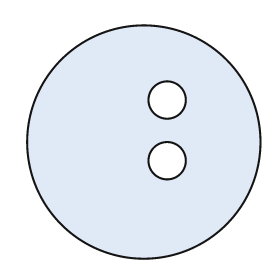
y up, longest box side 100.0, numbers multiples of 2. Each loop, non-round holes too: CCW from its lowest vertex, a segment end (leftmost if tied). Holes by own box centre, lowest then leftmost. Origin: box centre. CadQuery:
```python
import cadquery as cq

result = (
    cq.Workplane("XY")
    .moveTo(0.0, 0.0)
    .circle(50.0)
    .moveTo(10.0, -8.0)
    .circle(8.0)
    .moveTo(10.0, 18.0)
    .circle(8.0)
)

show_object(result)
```